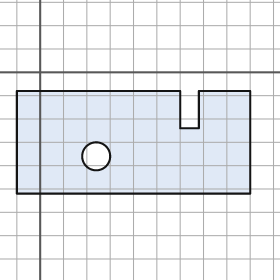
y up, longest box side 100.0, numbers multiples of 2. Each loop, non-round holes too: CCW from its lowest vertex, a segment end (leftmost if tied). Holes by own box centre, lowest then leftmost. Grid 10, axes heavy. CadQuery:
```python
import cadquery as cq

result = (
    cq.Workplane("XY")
    .moveTo(-10.0, -52.0)
    .lineTo(90.0, -52.0)
    .lineTo(90.0, -8.0)
    .lineTo(68.0, -8.0)
    .lineTo(68.0, -24.0)
    .lineTo(60.0, -24.0)
    .lineTo(60.0, -8.0)
    .lineTo(-10.0, -8.0)
    .close()
    .moveTo(24.0, -36.0)
    .circle(6.0)
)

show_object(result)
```